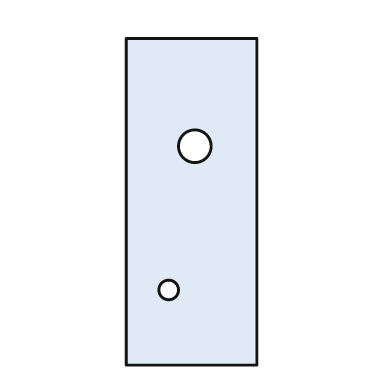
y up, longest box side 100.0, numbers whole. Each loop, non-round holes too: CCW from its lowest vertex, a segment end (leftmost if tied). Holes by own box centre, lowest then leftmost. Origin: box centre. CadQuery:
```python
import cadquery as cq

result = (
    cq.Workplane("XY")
    .moveTo(-20.0, -50.0)
    .lineTo(20.0, -50.0)
    .lineTo(20.0, 50.0)
    .lineTo(-20.0, 50.0)
    .close()
    .moveTo(-7.0, -27.0)
    .circle(3.0)
    .moveTo(1.0, 17.0)
    .circle(5.0)
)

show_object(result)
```